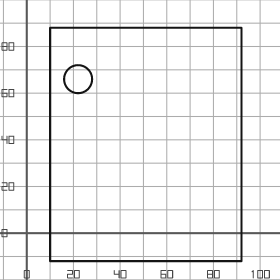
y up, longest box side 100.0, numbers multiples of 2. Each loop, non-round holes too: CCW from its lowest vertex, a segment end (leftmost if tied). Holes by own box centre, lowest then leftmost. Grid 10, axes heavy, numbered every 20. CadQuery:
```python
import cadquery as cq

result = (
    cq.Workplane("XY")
    .moveTo(10.0, -12.0)
    .lineTo(92.0, -12.0)
    .lineTo(92.0, 88.0)
    .lineTo(10.0, 88.0)
    .close()
    .moveTo(22.0, 66.0)
    .circle(6.0)
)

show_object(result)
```